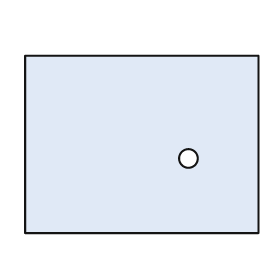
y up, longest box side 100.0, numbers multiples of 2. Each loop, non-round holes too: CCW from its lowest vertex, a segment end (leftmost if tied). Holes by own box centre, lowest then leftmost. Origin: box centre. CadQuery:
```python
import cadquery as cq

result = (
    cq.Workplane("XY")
    .moveTo(-50.0, -38.0)
    .lineTo(50.0, -38.0)
    .lineTo(50.0, 38.0)
    .lineTo(-50.0, 38.0)
    .close()
    .moveTo(20.0, -6.0)
    .circle(4.0)
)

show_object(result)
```